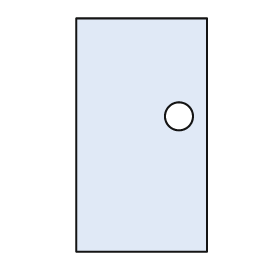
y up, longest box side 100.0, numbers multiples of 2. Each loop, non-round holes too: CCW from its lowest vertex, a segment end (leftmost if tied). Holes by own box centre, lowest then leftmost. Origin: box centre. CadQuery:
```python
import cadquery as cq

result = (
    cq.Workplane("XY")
    .moveTo(-28.0, -50.0)
    .lineTo(28.0, -50.0)
    .lineTo(28.0, 50.0)
    .lineTo(-28.0, 50.0)
    .close()
    .moveTo(16.0, 8.0)
    .circle(6.0)
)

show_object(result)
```